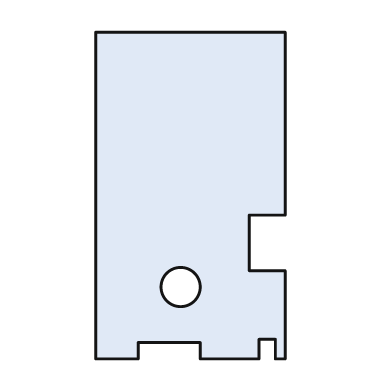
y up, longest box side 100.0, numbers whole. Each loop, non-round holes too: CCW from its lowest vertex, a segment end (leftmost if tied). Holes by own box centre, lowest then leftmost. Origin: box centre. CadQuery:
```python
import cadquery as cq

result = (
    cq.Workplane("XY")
    .moveTo(-29.0, -50.0)
    .lineTo(-16.0, -50.0)
    .lineTo(-16.0, -45.0)
    .lineTo(3.0, -45.0)
    .lineTo(3.0, -50.0)
    .lineTo(21.0, -50.0)
    .lineTo(21.0, -44.0)
    .lineTo(26.0, -44.0)
    .lineTo(26.0, -50.0)
    .lineTo(29.0, -50.0)
    .lineTo(29.0, -23.0)
    .lineTo(18.0, -23.0)
    .lineTo(18.0, -6.0)
    .lineTo(29.0, -6.0)
    .lineTo(29.0, 50.0)
    .lineTo(-29.0, 50.0)
    .close()
    .moveTo(-3.0, -28.0)
    .circle(6.0)
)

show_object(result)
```